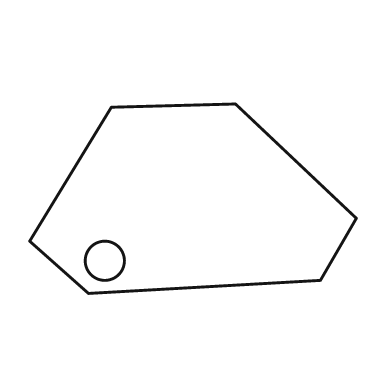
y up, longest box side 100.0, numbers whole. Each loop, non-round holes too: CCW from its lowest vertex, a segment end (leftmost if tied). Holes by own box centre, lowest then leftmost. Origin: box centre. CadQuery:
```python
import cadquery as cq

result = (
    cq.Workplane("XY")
    .moveTo(-32.0, -29.0)
    .lineTo(39.0, -25.0)
    .lineTo(50.0, -6.0)
    .lineTo(13.0, 29.0)
    .lineTo(-25.0, 28.0)
    .lineTo(-50.0, -13.0)
    .close()
    .moveTo(-27.0, -19.0)
    .circle(6.0)
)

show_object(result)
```